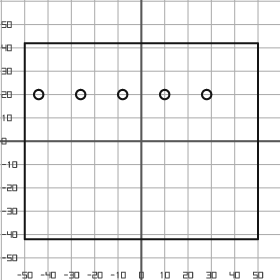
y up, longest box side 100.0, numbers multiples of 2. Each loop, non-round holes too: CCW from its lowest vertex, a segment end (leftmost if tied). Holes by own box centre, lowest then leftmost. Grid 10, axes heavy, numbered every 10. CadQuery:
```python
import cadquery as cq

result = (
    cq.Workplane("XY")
    .moveTo(-50.0, -42.0)
    .lineTo(50.0, -42.0)
    .lineTo(50.0, 42.0)
    .lineTo(-50.0, 42.0)
    .close()
    .moveTo(-44.0, 20.0)
    .circle(2.0)
    .moveTo(-26.0, 20.0)
    .circle(2.0)
    .moveTo(-8.0, 20.0)
    .circle(2.0)
    .moveTo(10.0, 20.0)
    .circle(2.0)
    .moveTo(28.0, 20.0)
    .circle(2.0)
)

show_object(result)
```